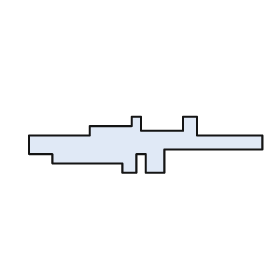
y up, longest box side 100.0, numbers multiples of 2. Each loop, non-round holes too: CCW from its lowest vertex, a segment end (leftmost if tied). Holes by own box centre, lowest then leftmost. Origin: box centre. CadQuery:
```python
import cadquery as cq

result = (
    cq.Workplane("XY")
    .moveTo(-10.0, -12.0)
    .lineTo(-4.0, -12.0)
    .lineTo(-4.0, -4.0)
    .lineTo(0.0, -4.0)
    .lineTo(0.0, -12.0)
    .lineTo(8.0, -12.0)
    .lineTo(8.0, -2.0)
    .lineTo(50.0, -2.0)
    .lineTo(50.0, 4.0)
    .lineTo(22.0, 4.0)
    .lineTo(22.0, 12.0)
    .lineTo(16.0, 12.0)
    .lineTo(16.0, 6.0)
    .lineTo(-2.0, 6.0)
    .lineTo(-2.0, 12.0)
    .lineTo(-6.0, 12.0)
    .lineTo(-6.0, 8.0)
    .lineTo(-24.0, 8.0)
    .lineTo(-24.0, 4.0)
    .lineTo(-50.0, 4.0)
    .lineTo(-50.0, -4.0)
    .lineTo(-40.0, -4.0)
    .lineTo(-40.0, -8.0)
    .lineTo(-10.0, -8.0)
    .close()
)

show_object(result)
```